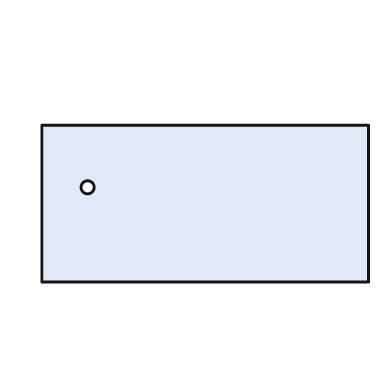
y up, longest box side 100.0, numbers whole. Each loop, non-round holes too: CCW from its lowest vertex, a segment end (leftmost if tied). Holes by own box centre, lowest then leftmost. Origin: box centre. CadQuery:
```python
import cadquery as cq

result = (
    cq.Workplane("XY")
    .moveTo(-50.0, -24.0)
    .lineTo(50.0, -24.0)
    .lineTo(50.0, 24.0)
    .lineTo(-50.0, 24.0)
    .close()
    .moveTo(-36.0, 5.0)
    .circle(2.0)
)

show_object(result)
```